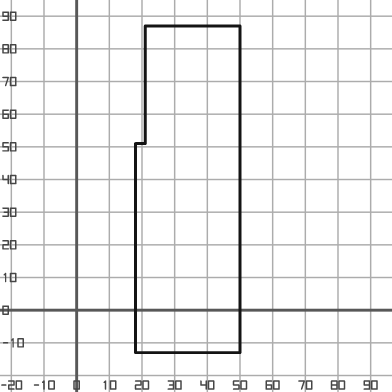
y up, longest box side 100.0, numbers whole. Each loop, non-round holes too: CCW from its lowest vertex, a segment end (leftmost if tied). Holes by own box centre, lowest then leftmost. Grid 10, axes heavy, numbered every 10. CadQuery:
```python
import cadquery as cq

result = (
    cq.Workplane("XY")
    .moveTo(18.0, -13.0)
    .lineTo(50.0, -13.0)
    .lineTo(50.0, 87.0)
    .lineTo(21.0, 87.0)
    .lineTo(21.0, 51.0)
    .lineTo(18.0, 51.0)
    .close()
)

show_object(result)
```